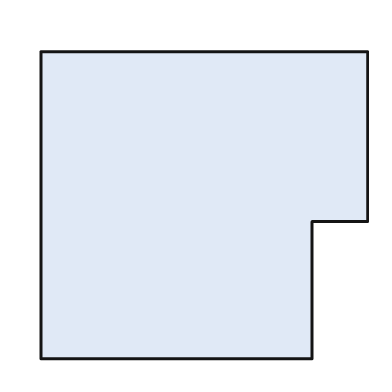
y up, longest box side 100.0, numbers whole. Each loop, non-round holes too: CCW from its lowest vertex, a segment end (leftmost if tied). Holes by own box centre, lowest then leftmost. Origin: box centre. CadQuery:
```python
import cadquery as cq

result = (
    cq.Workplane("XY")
    .moveTo(-50.0, -47.0)
    .lineTo(33.0, -47.0)
    .lineTo(33.0, -5.0)
    .lineTo(50.0, -5.0)
    .lineTo(50.0, 47.0)
    .lineTo(-50.0, 47.0)
    .close()
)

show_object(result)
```